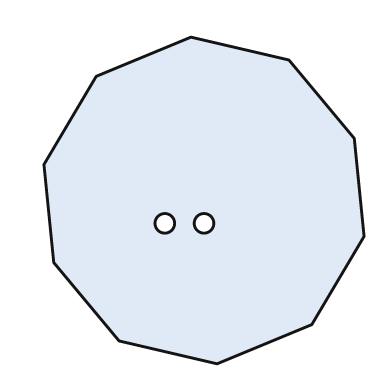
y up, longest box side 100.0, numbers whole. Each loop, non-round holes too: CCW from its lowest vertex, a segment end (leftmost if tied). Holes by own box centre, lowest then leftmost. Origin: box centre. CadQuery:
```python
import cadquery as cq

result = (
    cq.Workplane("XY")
    .moveTo(4.0, -50.0)
    .lineTo(33.0, -38.0)
    .lineTo(49.0, -11.0)
    .lineTo(46.0, 19.0)
    .lineTo(26.0, 43.0)
    .lineTo(-4.0, 50.0)
    .lineTo(-33.0, 38.0)
    .lineTo(-49.0, 11.0)
    .lineTo(-46.0, -19.0)
    .lineTo(-26.0, -43.0)
    .close()
    .moveTo(-12.0, -7.0)
    .circle(3.0)
    .moveTo(0.0, -7.0)
    .circle(3.0)
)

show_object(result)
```